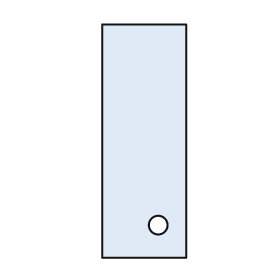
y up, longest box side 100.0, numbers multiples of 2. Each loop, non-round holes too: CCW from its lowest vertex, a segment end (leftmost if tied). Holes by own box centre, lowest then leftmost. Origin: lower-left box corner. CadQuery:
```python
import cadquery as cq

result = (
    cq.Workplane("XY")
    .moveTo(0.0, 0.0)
    .lineTo(36.0, 0.0)
    .lineTo(36.0, 100.0)
    .lineTo(0.0, 100.0)
    .close()
    .moveTo(24.0, 14.0)
    .circle(4.0)
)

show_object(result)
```